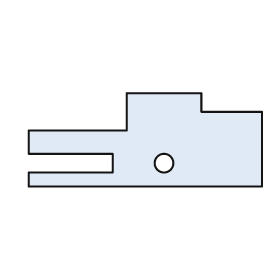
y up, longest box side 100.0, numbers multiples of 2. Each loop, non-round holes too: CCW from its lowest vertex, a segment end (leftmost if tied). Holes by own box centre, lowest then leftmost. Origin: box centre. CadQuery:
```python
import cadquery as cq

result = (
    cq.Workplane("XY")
    .moveTo(-50.0, -20.0)
    .lineTo(50.0, -20.0)
    .lineTo(50.0, 12.0)
    .lineTo(24.0, 12.0)
    .lineTo(24.0, 20.0)
    .lineTo(-8.0, 20.0)
    .lineTo(-8.0, 4.0)
    .lineTo(-50.0, 4.0)
    .lineTo(-50.0, -6.0)
    .lineTo(-14.0, -6.0)
    .lineTo(-14.0, -14.0)
    .lineTo(-50.0, -14.0)
    .close()
    .moveTo(8.0, -10.0)
    .circle(4.0)
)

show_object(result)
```